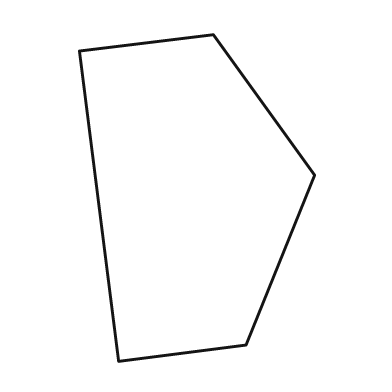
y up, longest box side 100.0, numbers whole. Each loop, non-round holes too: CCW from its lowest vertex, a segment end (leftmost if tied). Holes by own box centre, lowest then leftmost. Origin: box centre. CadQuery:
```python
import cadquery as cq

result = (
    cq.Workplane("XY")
    .moveTo(-24.0, -50.0)
    .lineTo(15.0, -45.0)
    .lineTo(36.0, 7.0)
    .lineTo(5.0, 50.0)
    .lineTo(-36.0, 45.0)
    .close()
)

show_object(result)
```